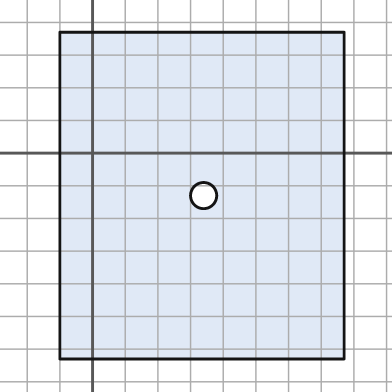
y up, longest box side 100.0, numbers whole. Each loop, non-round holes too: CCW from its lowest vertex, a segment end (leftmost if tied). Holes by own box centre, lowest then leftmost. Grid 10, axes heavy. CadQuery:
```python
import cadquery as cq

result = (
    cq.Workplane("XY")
    .moveTo(-10.0, -63.0)
    .lineTo(77.0, -63.0)
    .lineTo(77.0, 37.0)
    .lineTo(-10.0, 37.0)
    .close()
    .moveTo(34.0, -13.0)
    .circle(4.0)
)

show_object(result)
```